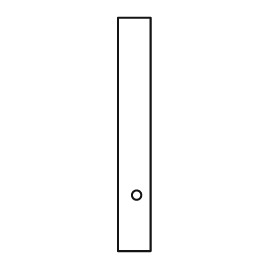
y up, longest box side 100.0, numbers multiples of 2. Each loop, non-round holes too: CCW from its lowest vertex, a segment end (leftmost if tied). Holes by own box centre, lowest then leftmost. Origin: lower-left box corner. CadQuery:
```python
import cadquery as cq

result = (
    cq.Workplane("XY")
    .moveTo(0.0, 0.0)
    .lineTo(14.0, 0.0)
    .lineTo(14.0, 100.0)
    .lineTo(0.0, 100.0)
    .close()
    .moveTo(8.0, 24.0)
    .circle(2.0)
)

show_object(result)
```